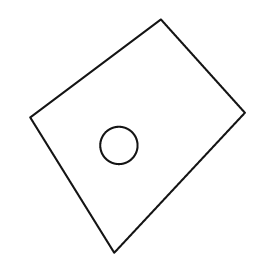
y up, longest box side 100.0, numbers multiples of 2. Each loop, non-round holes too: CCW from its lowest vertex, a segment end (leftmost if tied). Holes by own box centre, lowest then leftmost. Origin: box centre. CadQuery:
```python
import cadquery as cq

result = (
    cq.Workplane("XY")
    .moveTo(-10.0, -50.0)
    .lineTo(46.0, 10.0)
    .lineTo(10.0, 50.0)
    .lineTo(-46.0, 8.0)
    .close()
    .moveTo(-8.0, -4.0)
    .circle(8.0)
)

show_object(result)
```